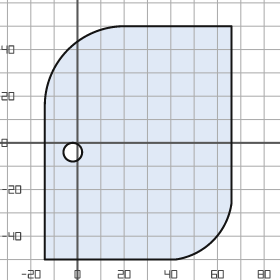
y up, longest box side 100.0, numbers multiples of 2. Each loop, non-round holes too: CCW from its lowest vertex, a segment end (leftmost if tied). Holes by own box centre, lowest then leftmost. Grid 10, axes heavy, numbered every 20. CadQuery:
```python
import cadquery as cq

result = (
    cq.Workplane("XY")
    .moveTo(-14.0, -50.0)
    .lineTo(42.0, -50.0)
    .threePointArc((58.0, -42.0), (66.0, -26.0))
    .lineTo(66.0, 50.0)
    .lineTo(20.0, 50.0)
    .threePointArc((-4.0, 40.0), (-14.0, 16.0))
    .close()
    .moveTo(-2.0, -4.0)
    .circle(4.0)
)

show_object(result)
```